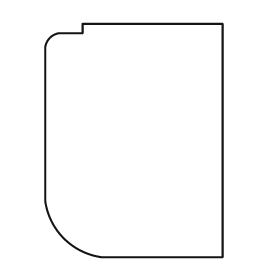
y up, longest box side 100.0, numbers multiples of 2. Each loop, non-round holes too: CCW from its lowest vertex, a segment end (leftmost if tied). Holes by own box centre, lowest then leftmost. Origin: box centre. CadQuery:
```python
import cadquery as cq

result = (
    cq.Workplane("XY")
    .moveTo(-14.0, -50.0)
    .lineTo(38.0, -50.0)
    .lineTo(38.0, 50.0)
    .lineTo(-22.0, 50.0)
    .lineTo(-22.0, 46.0)
    .lineTo(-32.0, 46.0)
    .threePointArc((-36.0, 44.0), (-38.0, 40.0))
    .lineTo(-38.0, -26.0)
    .threePointArc((-30.0, -42.0), (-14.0, -50.0))
    .close()
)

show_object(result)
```